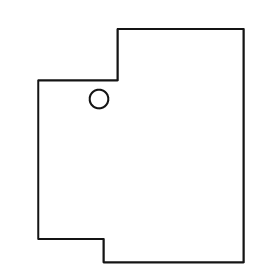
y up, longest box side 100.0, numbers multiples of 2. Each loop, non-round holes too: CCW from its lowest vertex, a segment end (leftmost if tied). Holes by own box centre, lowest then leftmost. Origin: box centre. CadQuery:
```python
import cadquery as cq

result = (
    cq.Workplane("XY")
    .moveTo(-16.0, -50.0)
    .lineTo(44.0, -50.0)
    .lineTo(44.0, 50.0)
    .lineTo(-10.0, 50.0)
    .lineTo(-10.0, 28.0)
    .lineTo(-44.0, 28.0)
    .lineTo(-44.0, -40.0)
    .lineTo(-16.0, -40.0)
    .close()
    .moveTo(-18.0, 20.0)
    .circle(4.0)
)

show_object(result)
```